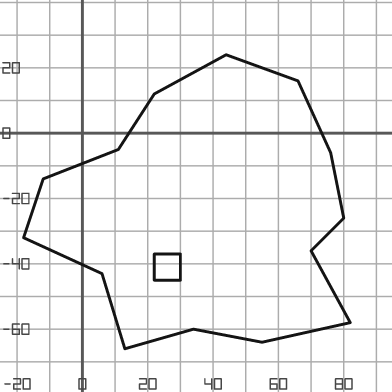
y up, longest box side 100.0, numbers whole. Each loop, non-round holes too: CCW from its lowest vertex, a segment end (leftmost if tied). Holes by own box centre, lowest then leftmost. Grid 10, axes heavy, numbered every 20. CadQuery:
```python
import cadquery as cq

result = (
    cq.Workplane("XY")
    .moveTo(13.0, -66.0)
    .lineTo(34.0, -60.0)
    .lineTo(55.0, -64.0)
    .lineTo(82.0, -58.0)
    .lineTo(70.0, -36.0)
    .lineTo(80.0, -26.0)
    .lineTo(76.0, -6.0)
    .lineTo(66.0, 16.0)
    .lineTo(44.0, 24.0)
    .lineTo(22.0, 12.0)
    .lineTo(11.0, -5.0)
    .lineTo(-12.0, -14.0)
    .lineTo(-18.0, -32.0)
    .lineTo(6.0, -43.0)
    .close()
    .moveTo(22.0, -45.0)
    .lineTo(30.0, -45.0)
    .lineTo(30.0, -37.0)
    .lineTo(22.0, -37.0)
    .close()
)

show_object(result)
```